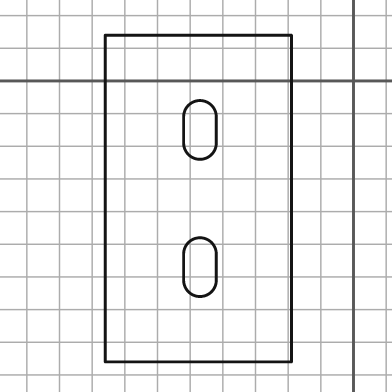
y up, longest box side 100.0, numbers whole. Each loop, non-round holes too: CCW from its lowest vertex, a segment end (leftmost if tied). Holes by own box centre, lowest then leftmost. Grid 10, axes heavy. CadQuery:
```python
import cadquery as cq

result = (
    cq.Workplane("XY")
    .moveTo(-76.0, -86.0)
    .lineTo(-19.0, -86.0)
    .lineTo(-19.0, 14.0)
    .lineTo(-76.0, 14.0)
    .close()
    .moveTo(-52.0, -61.0)
    .threePointArc((-47.0, -66.0), (-42.0, -61.0))
    .lineTo(-42.0, -53.0)
    .threePointArc((-47.0, -48.0), (-52.0, -53.0))
    .close()
    .moveTo(-52.0, -19.0)
    .threePointArc((-47.0, -24.0), (-42.0, -19.0))
    .lineTo(-42.0, -11.0)
    .threePointArc((-47.0, -6.0), (-52.0, -11.0))
    .close()
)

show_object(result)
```